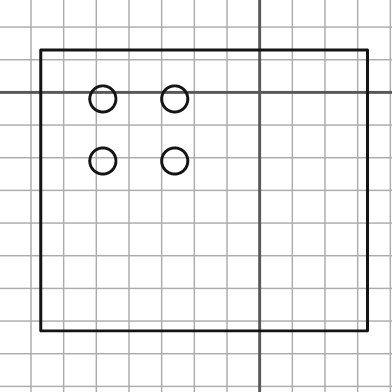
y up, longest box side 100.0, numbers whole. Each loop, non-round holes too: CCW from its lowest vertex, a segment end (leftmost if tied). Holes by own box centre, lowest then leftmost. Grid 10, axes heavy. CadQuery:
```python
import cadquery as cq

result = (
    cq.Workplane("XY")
    .moveTo(-67.0, -73.0)
    .lineTo(33.0, -73.0)
    .lineTo(33.0, 13.0)
    .lineTo(-67.0, 13.0)
    .close()
    .moveTo(-48.0, -21.0)
    .circle(4.0)
    .moveTo(-26.0, -21.0)
    .circle(4.0)
    .moveTo(-48.0, -2.0)
    .circle(4.0)
    .moveTo(-26.0, -2.0)
    .circle(4.0)
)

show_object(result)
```